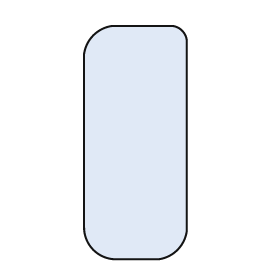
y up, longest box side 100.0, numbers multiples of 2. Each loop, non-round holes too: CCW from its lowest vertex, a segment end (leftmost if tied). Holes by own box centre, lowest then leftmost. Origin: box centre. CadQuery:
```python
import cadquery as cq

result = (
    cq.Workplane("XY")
    .moveTo(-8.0, -50.0)
    .lineTo(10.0, -50.0)
    .threePointArc((18.0, -46.0), (22.0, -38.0))
    .lineTo(22.0, 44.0)
    .threePointArc((20.0, 48.0), (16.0, 50.0))
    .lineTo(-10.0, 50.0)
    .threePointArc((-18.0, 46.0), (-22.0, 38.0))
    .lineTo(-22.0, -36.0)
    .threePointArc((-18.0, -46.0), (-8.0, -50.0))
    .close()
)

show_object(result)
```